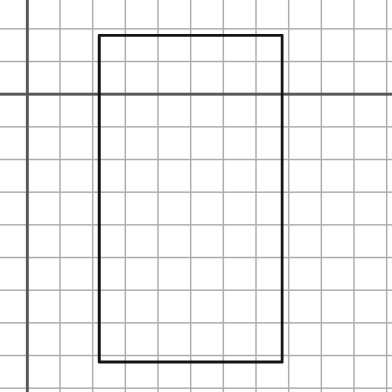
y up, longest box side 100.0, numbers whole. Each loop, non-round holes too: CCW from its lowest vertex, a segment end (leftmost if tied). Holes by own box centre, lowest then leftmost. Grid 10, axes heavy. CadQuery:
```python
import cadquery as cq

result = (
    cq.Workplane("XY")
    .moveTo(22.0, -82.0)
    .lineTo(78.0, -82.0)
    .lineTo(78.0, 18.0)
    .lineTo(22.0, 18.0)
    .close()
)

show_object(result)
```